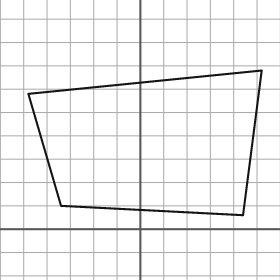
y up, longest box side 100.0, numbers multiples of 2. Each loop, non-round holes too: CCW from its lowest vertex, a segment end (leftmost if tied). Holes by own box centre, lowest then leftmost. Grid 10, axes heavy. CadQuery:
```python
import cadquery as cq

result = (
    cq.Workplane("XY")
    .moveTo(44.0, 6.0)
    .lineTo(52.0, 68.0)
    .lineTo(-48.0, 58.0)
    .lineTo(-34.0, 10.0)
    .close()
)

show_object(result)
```